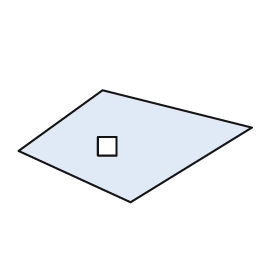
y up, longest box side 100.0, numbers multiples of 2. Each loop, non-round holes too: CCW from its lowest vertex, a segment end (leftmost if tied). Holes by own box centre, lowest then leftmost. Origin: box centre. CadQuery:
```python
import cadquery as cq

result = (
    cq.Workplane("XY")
    .moveTo(-2.0, -24.0)
    .lineTo(50.0, 8.0)
    .lineTo(-14.0, 24.0)
    .lineTo(-50.0, -2.0)
    .close()
    .moveTo(-16.0, -4.0)
    .lineTo(-8.0, -4.0)
    .lineTo(-8.0, 4.0)
    .lineTo(-16.0, 4.0)
    .close()
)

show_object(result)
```